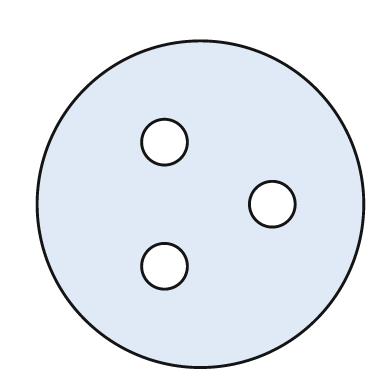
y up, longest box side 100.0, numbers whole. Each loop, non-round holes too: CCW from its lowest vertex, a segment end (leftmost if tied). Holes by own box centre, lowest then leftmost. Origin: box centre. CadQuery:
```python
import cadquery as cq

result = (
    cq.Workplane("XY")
    .moveTo(0.0, 0.0)
    .circle(50.0)
    .moveTo(-11.0, -19.0)
    .circle(7.0)
    .moveTo(22.0, 0.0)
    .circle(7.0)
    .moveTo(-11.0, 19.0)
    .circle(7.0)
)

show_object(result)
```